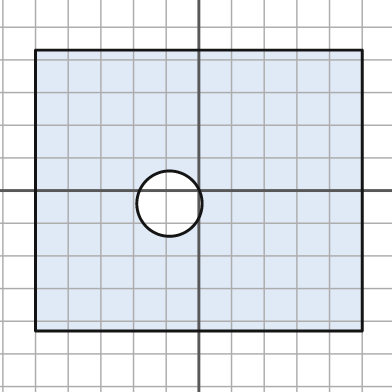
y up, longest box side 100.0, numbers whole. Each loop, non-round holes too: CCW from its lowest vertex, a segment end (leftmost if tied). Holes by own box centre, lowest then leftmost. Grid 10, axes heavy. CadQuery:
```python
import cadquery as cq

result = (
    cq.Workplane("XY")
    .moveTo(-50.0, -43.0)
    .lineTo(50.0, -43.0)
    .lineTo(50.0, 43.0)
    .lineTo(-50.0, 43.0)
    .close()
    .moveTo(-9.0, -4.0)
    .circle(10.0)
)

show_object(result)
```